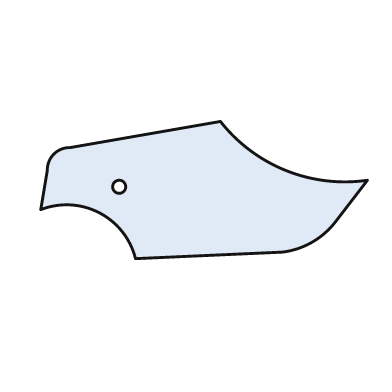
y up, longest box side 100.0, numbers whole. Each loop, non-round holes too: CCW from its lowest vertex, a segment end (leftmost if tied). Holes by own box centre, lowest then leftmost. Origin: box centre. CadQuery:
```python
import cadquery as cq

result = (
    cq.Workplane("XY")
    .moveTo(-21.0, -21.0)
    .lineTo(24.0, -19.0)
    .threePointArc((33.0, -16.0), (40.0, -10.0))
    .lineTo(50.0, 3.0)
    .threePointArc((25.0, 6.0), (5.0, 21.0))
    .lineTo(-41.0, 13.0)
    .threePointArc((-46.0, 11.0), (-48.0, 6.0))
    .lineTo(-50.0, -6.0)
    .threePointArc((-32.0, -7.0), (-21.0, -21.0))
    .close()
    .moveTo(-26.0, 1.0)
    .circle(2.0)
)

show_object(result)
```